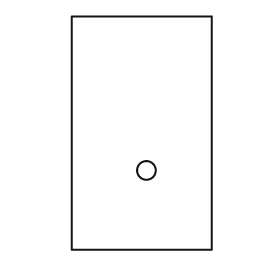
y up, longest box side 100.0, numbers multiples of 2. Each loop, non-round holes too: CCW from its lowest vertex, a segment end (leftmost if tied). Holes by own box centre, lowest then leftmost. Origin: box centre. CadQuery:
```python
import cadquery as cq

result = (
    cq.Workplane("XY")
    .moveTo(-30.0, -50.0)
    .lineTo(30.0, -50.0)
    .lineTo(30.0, 50.0)
    .lineTo(-30.0, 50.0)
    .close()
    .moveTo(2.0, -16.0)
    .circle(4.0)
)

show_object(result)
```